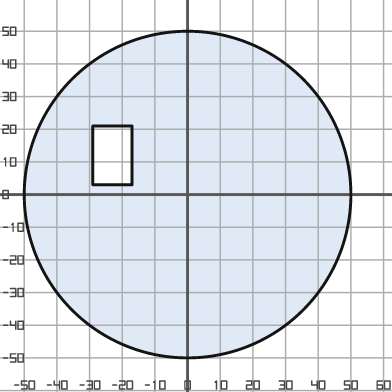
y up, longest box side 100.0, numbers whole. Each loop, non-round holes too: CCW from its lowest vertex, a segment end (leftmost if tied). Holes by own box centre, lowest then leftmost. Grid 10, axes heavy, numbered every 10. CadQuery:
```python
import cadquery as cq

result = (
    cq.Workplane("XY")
    .moveTo(0.0, 0.0)
    .circle(50.0)
    .moveTo(-29.0, 3.0)
    .lineTo(-17.0, 3.0)
    .lineTo(-17.0, 21.0)
    .lineTo(-29.0, 21.0)
    .close()
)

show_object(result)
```